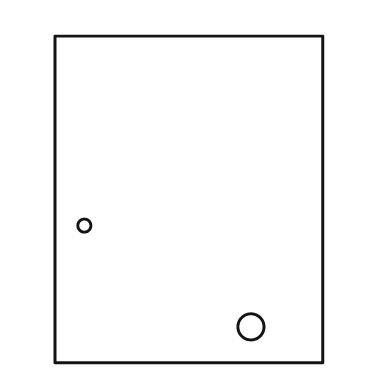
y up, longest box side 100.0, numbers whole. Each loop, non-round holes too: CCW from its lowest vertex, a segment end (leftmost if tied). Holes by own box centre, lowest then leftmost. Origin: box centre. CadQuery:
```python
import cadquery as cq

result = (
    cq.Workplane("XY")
    .moveTo(-41.0, -50.0)
    .lineTo(41.0, -50.0)
    .lineTo(41.0, 50.0)
    .lineTo(-41.0, 50.0)
    .close()
    .moveTo(19.0, -39.0)
    .circle(4.0)
    .moveTo(-32.0, -8.0)
    .circle(2.0)
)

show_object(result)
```